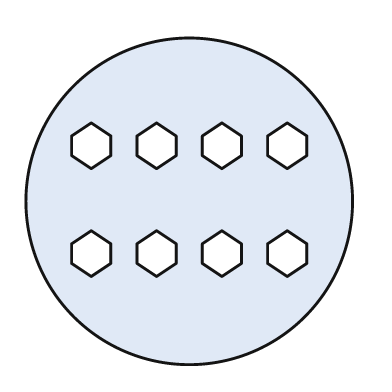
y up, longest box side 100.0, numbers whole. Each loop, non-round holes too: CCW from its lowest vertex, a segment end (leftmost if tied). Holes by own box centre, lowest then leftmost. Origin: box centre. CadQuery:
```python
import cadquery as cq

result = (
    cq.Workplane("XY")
    .moveTo(0.0, 0.0)
    .circle(50.0)
    .moveTo(-30.0, -23.0)
    .lineTo(-24.0, -19.0)
    .lineTo(-24.0, -13.0)
    .lineTo(-30.0, -9.0)
    .lineTo(-36.0, -13.0)
    .lineTo(-36.0, -19.0)
    .close()
    .moveTo(-10.0, -23.0)
    .lineTo(-4.0, -19.0)
    .lineTo(-4.0, -13.0)
    .lineTo(-10.0, -9.0)
    .lineTo(-16.0, -13.0)
    .lineTo(-16.0, -19.0)
    .close()
    .moveTo(10.0, -23.0)
    .lineTo(16.0, -19.0)
    .lineTo(16.0, -13.0)
    .lineTo(10.0, -9.0)
    .lineTo(4.0, -13.0)
    .lineTo(4.0, -19.0)
    .close()
    .moveTo(30.0, -23.0)
    .lineTo(36.0, -19.0)
    .lineTo(36.0, -13.0)
    .lineTo(30.0, -9.0)
    .lineTo(24.0, -13.0)
    .lineTo(24.0, -19.0)
    .close()
    .moveTo(-30.0, 10.0)
    .lineTo(-24.0, 14.0)
    .lineTo(-24.0, 20.0)
    .lineTo(-30.0, 24.0)
    .lineTo(-36.0, 20.0)
    .lineTo(-36.0, 14.0)
    .close()
    .moveTo(-10.0, 10.0)
    .lineTo(-4.0, 14.0)
    .lineTo(-4.0, 20.0)
    .lineTo(-10.0, 24.0)
    .lineTo(-16.0, 20.0)
    .lineTo(-16.0, 14.0)
    .close()
    .moveTo(10.0, 10.0)
    .lineTo(16.0, 14.0)
    .lineTo(16.0, 20.0)
    .lineTo(10.0, 24.0)
    .lineTo(4.0, 20.0)
    .lineTo(4.0, 14.0)
    .close()
    .moveTo(30.0, 10.0)
    .lineTo(36.0, 14.0)
    .lineTo(36.0, 20.0)
    .lineTo(30.0, 24.0)
    .lineTo(24.0, 20.0)
    .lineTo(24.0, 14.0)
    .close()
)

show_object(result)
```